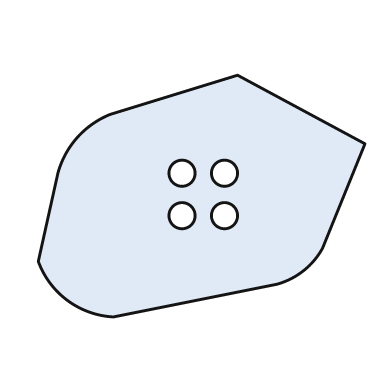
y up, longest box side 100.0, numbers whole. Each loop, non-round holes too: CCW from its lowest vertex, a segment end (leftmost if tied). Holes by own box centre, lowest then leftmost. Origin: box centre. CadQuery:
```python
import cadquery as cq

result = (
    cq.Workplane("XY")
    .moveTo(-27.0, -37.0)
    .lineTo(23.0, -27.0)
    .threePointArc((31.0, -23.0), (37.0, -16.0))
    .lineTo(50.0, 16.0)
    .lineTo(11.0, 37.0)
    .lineTo(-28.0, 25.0)
    .threePointArc((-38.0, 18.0), (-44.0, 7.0))
    .lineTo(-50.0, -20.0)
    .threePointArc((-41.0, -32.0), (-27.0, -37.0))
    .close()
    .moveTo(-6.0, -6.0)
    .circle(4.0)
    .moveTo(7.0, -6.0)
    .circle(4.0)
    .moveTo(-6.0, 7.0)
    .circle(4.0)
    .moveTo(7.0, 7.0)
    .circle(4.0)
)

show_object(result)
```